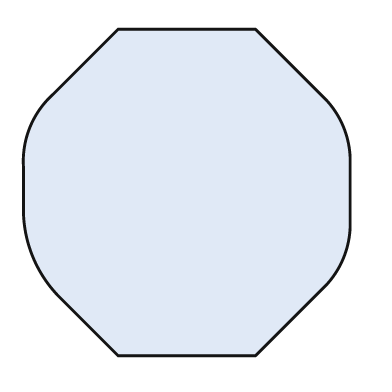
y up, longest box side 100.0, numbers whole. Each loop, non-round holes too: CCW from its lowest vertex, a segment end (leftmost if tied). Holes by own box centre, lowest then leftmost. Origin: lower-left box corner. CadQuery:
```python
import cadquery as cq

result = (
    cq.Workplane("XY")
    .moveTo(29.0, 0.0)
    .lineTo(71.0, 0.0)
    .lineTo(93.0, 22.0)
    .threePointArc((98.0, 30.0), (100.0, 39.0))
    .lineTo(100.0, 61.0)
    .threePointArc((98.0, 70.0), (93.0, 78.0))
    .lineTo(71.0, 100.0)
    .lineTo(29.0, 100.0)
    .lineTo(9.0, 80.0)
    .threePointArc((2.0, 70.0), (0.0, 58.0))
    .lineTo(0.0, 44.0)
    .threePointArc((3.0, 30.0), (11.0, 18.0))
    .close()
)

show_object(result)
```